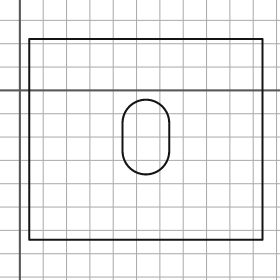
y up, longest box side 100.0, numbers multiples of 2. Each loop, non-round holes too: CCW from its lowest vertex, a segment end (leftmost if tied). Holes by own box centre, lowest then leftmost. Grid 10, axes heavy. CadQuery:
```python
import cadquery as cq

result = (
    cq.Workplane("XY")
    .moveTo(4.0, -64.0)
    .lineTo(104.0, -64.0)
    .lineTo(104.0, 22.0)
    .lineTo(4.0, 22.0)
    .close()
    .moveTo(44.0, -26.0)
    .threePointArc((54.0, -36.0), (64.0, -26.0))
    .lineTo(64.0, -14.0)
    .threePointArc((54.0, -4.0), (44.0, -14.0))
    .close()
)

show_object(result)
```